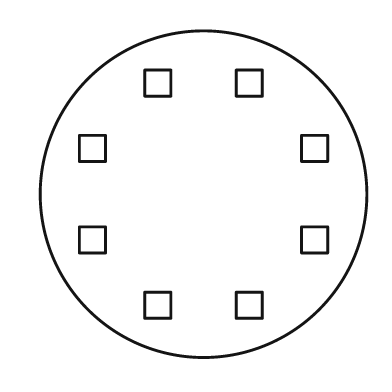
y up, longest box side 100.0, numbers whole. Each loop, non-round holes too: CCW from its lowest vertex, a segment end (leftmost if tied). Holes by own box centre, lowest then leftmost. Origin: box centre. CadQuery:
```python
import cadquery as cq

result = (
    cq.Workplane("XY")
    .moveTo(0.0, 0.0)
    .circle(50.0)
    .moveTo(-18.0, -38.0)
    .lineTo(-10.0, -38.0)
    .lineTo(-10.0, -30.0)
    .lineTo(-18.0, -30.0)
    .close()
    .moveTo(10.0, -38.0)
    .lineTo(18.0, -38.0)
    .lineTo(18.0, -30.0)
    .lineTo(10.0, -30.0)
    .close()
    .moveTo(-38.0, -18.0)
    .lineTo(-30.0, -18.0)
    .lineTo(-30.0, -10.0)
    .lineTo(-38.0, -10.0)
    .close()
    .moveTo(30.0, -18.0)
    .lineTo(38.0, -18.0)
    .lineTo(38.0, -10.0)
    .lineTo(30.0, -10.0)
    .close()
    .moveTo(-38.0, 10.0)
    .lineTo(-30.0, 10.0)
    .lineTo(-30.0, 18.0)
    .lineTo(-38.0, 18.0)
    .close()
    .moveTo(30.0, 10.0)
    .lineTo(38.0, 10.0)
    .lineTo(38.0, 18.0)
    .lineTo(30.0, 18.0)
    .close()
    .moveTo(-18.0, 30.0)
    .lineTo(-10.0, 30.0)
    .lineTo(-10.0, 38.0)
    .lineTo(-18.0, 38.0)
    .close()
    .moveTo(10.0, 30.0)
    .lineTo(18.0, 30.0)
    .lineTo(18.0, 38.0)
    .lineTo(10.0, 38.0)
    .close()
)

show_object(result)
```